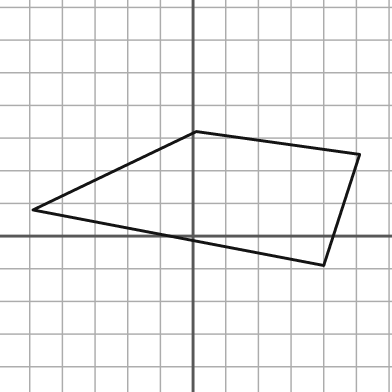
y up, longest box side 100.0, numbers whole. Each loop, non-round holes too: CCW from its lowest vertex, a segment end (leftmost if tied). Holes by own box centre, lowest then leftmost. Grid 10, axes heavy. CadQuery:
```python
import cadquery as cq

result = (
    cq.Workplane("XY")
    .moveTo(40.0, -9.0)
    .lineTo(51.0, 25.0)
    .lineTo(1.0, 32.0)
    .lineTo(-49.0, 8.0)
    .close()
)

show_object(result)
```